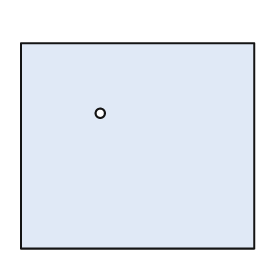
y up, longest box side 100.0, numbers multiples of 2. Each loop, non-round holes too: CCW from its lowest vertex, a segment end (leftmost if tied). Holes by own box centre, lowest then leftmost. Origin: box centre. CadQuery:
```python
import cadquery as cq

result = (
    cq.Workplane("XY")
    .moveTo(-50.0, -44.0)
    .lineTo(50.0, -44.0)
    .lineTo(50.0, 44.0)
    .lineTo(-50.0, 44.0)
    .close()
    .moveTo(-16.0, 14.0)
    .circle(2.0)
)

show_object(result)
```